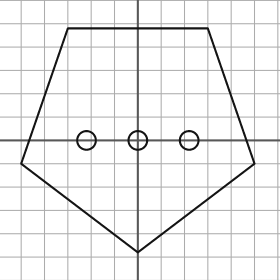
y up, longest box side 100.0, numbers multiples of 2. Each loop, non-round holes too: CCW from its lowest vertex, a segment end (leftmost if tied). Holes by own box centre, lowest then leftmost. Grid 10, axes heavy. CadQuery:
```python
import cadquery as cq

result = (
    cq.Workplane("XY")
    .moveTo(0.0, -48.0)
    .lineTo(50.0, -10.0)
    .lineTo(30.0, 48.0)
    .lineTo(-30.0, 48.0)
    .lineTo(-50.0, -10.0)
    .close()
    .moveTo(-22.0, 0.0)
    .circle(4.0)
    .moveTo(0.0, 0.0)
    .circle(4.0)
    .moveTo(22.0, 0.0)
    .circle(4.0)
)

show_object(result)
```